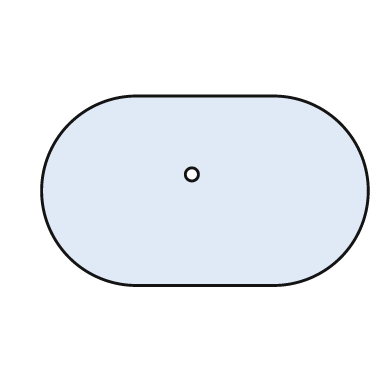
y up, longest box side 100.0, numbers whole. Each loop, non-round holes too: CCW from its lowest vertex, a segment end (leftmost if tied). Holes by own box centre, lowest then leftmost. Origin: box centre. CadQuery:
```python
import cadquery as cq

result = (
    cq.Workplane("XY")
    .moveTo(-21.0, -29.0)
    .lineTo(21.0, -29.0)
    .threePointArc((50.0, 0.0), (21.0, 29.0))
    .lineTo(-21.0, 29.0)
    .threePointArc((-50.0, 0.0), (-21.0, -29.0))
    .close()
    .moveTo(-4.0, 5.0)
    .circle(2.0)
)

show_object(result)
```